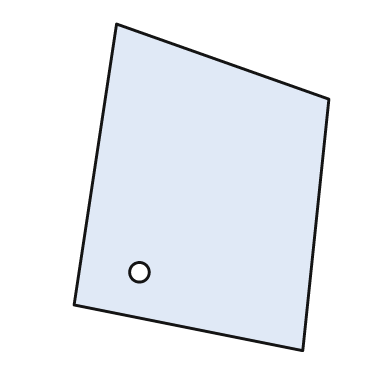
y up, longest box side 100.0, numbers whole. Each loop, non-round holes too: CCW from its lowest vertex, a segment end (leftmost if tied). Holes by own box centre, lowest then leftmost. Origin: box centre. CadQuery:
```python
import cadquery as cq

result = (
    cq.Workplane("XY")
    .moveTo(31.0, -50.0)
    .lineTo(39.0, 27.0)
    .lineTo(-26.0, 50.0)
    .lineTo(-39.0, -36.0)
    .close()
    .moveTo(-19.0, -26.0)
    .circle(3.0)
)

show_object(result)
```